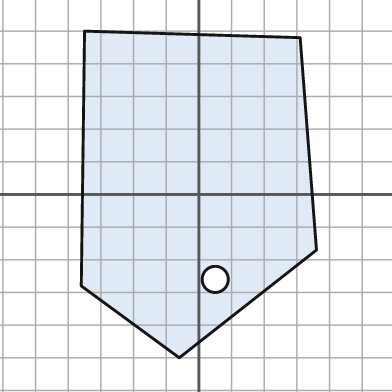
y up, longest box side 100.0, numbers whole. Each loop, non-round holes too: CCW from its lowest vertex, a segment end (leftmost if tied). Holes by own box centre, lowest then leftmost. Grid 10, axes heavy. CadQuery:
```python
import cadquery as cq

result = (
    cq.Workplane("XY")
    .moveTo(-6.0, -50.0)
    .lineTo(36.0, -17.0)
    .lineTo(31.0, 48.0)
    .lineTo(-35.0, 50.0)
    .lineTo(-36.0, -28.0)
    .close()
    .moveTo(5.0, -26.0)
    .circle(4.0)
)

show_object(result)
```